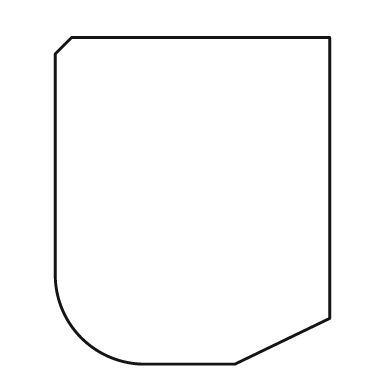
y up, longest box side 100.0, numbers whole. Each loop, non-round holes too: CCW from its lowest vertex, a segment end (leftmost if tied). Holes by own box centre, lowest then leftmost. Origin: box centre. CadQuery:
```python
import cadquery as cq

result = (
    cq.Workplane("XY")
    .moveTo(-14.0, -50.0)
    .lineTo(13.0, -50.0)
    .lineTo(42.0, -36.0)
    .lineTo(42.0, 50.0)
    .lineTo(-37.0, 50.0)
    .lineTo(-42.0, 45.0)
    .lineTo(-42.0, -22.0)
    .threePointArc((-34.0, -42.0), (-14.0, -50.0))
    .close()
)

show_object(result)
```